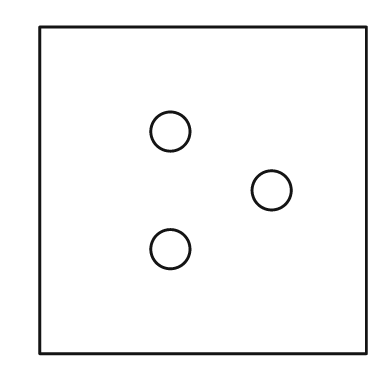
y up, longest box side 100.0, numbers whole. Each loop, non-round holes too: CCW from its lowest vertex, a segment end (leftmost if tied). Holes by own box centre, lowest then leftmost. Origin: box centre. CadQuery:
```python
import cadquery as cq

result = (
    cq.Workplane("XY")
    .moveTo(-50.0, -50.0)
    .lineTo(50.0, -50.0)
    .lineTo(50.0, 50.0)
    .lineTo(-50.0, 50.0)
    .close()
    .moveTo(-10.0, -18.0)
    .circle(6.0)
    .moveTo(21.0, 0.0)
    .circle(6.0)
    .moveTo(-10.0, 18.0)
    .circle(6.0)
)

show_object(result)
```